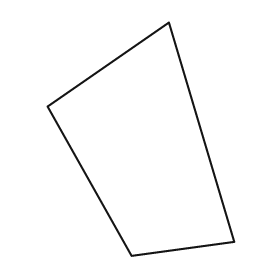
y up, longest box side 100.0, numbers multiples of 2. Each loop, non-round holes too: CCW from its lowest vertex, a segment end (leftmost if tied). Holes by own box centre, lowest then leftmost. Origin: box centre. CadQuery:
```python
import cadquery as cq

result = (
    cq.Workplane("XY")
    .moveTo(-4.0, -50.0)
    .lineTo(40.0, -44.0)
    .lineTo(12.0, 50.0)
    .lineTo(-40.0, 14.0)
    .close()
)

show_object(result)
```